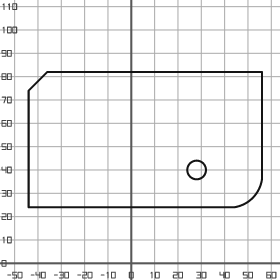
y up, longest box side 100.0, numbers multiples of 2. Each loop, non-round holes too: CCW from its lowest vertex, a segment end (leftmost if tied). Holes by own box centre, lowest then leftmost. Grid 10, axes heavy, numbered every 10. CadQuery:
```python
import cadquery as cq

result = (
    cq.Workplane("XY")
    .moveTo(-44.0, 24.0)
    .lineTo(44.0, 24.0)
    .threePointArc((52.0, 28.0), (56.0, 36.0))
    .lineTo(56.0, 82.0)
    .lineTo(-36.0, 82.0)
    .lineTo(-44.0, 74.0)
    .close()
    .moveTo(28.0, 40.0)
    .circle(4.0)
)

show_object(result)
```